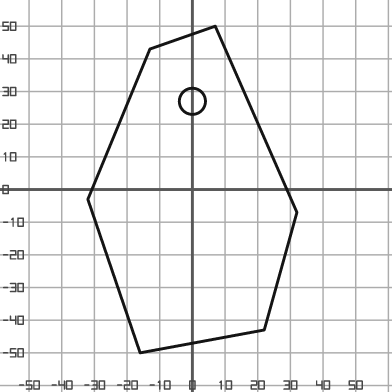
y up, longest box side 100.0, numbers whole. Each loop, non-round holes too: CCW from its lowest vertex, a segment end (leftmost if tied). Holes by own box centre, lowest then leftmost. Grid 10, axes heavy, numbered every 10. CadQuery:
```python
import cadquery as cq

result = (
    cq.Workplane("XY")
    .moveTo(-16.0, -50.0)
    .lineTo(22.0, -43.0)
    .lineTo(32.0, -7.0)
    .lineTo(7.0, 50.0)
    .lineTo(-13.0, 43.0)
    .lineTo(-32.0, -3.0)
    .close()
    .moveTo(0.0, 27.0)
    .circle(4.0)
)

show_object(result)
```